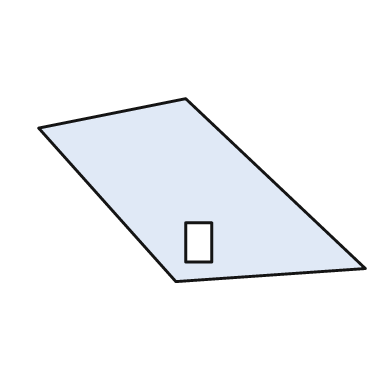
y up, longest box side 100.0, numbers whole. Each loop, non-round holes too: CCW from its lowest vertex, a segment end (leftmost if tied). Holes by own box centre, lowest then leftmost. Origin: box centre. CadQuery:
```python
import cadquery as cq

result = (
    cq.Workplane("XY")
    .moveTo(-8.0, -28.0)
    .lineTo(50.0, -24.0)
    .lineTo(-5.0, 28.0)
    .lineTo(-50.0, 19.0)
    .close()
    .moveTo(-5.0, -22.0)
    .lineTo(3.0, -22.0)
    .lineTo(3.0, -10.0)
    .lineTo(-5.0, -10.0)
    .close()
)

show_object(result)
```